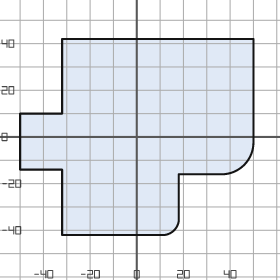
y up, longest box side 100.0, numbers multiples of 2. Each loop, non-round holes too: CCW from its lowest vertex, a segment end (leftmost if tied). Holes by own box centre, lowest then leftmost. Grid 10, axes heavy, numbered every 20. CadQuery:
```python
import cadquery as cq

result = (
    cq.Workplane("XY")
    .moveTo(-32.0, -42.0)
    .lineTo(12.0, -42.0)
    .threePointArc((16.0, -40.0), (18.0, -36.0))
    .lineTo(18.0, -16.0)
    .lineTo(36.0, -16.0)
    .threePointArc((46.0, -12.0), (50.0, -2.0))
    .lineTo(50.0, 42.0)
    .lineTo(-32.0, 42.0)
    .lineTo(-32.0, 10.0)
    .lineTo(-50.0, 10.0)
    .lineTo(-50.0, -14.0)
    .lineTo(-32.0, -14.0)
    .close()
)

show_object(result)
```